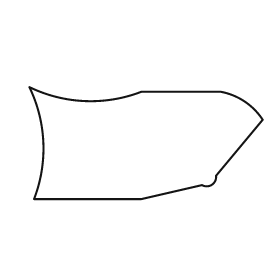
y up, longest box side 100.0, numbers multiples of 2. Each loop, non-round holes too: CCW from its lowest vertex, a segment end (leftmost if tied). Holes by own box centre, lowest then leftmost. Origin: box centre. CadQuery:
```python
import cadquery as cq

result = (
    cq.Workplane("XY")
    .moveTo(-48.0, -24.0)
    .lineTo(-2.0, -24.0)
    .lineTo(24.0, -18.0)
    .threePointArc((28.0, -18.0), (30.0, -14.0))
    .lineTo(50.0, 10.0)
    .threePointArc((42.0, 18.0), (32.0, 22.0))
    .lineTo(-2.0, 22.0)
    .threePointArc((-26.0, 18.0), (-50.0, 24.0))
    .threePointArc((-44.0, 0.0), (-48.0, -24.0))
    .close()
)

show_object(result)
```